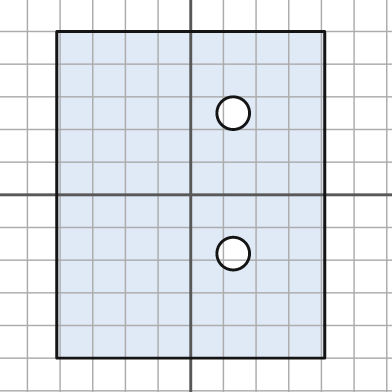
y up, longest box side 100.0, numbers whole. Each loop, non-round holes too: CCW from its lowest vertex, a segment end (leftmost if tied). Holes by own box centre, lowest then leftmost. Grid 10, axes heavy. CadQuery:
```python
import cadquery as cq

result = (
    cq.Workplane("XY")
    .moveTo(-41.0, -50.0)
    .lineTo(41.0, -50.0)
    .lineTo(41.0, 50.0)
    .lineTo(-41.0, 50.0)
    .close()
    .moveTo(13.0, -18.0)
    .circle(5.0)
    .moveTo(13.0, 25.0)
    .circle(5.0)
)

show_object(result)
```